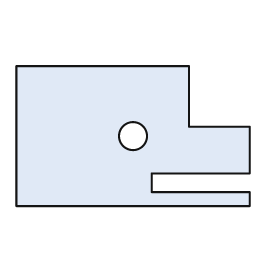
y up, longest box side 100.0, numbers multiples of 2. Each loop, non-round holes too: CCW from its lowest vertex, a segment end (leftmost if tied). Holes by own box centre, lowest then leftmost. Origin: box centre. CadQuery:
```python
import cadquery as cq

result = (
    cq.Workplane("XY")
    .moveTo(-50.0, -30.0)
    .lineTo(50.0, -30.0)
    .lineTo(50.0, -24.0)
    .lineTo(8.0, -24.0)
    .lineTo(8.0, -16.0)
    .lineTo(50.0, -16.0)
    .lineTo(50.0, 4.0)
    .lineTo(24.0, 4.0)
    .lineTo(24.0, 30.0)
    .lineTo(-50.0, 30.0)
    .close()
    .moveTo(0.0, 0.0)
    .circle(6.0)
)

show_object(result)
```